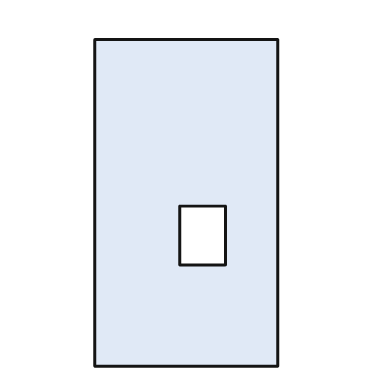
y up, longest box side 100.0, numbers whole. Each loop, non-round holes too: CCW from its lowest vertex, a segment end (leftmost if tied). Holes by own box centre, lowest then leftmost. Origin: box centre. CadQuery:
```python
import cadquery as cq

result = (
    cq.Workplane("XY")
    .moveTo(-28.0, -50.0)
    .lineTo(28.0, -50.0)
    .lineTo(28.0, 50.0)
    .lineTo(-28.0, 50.0)
    .close()
    .moveTo(-2.0, -19.0)
    .lineTo(12.0, -19.0)
    .lineTo(12.0, -1.0)
    .lineTo(-2.0, -1.0)
    .close()
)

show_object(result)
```